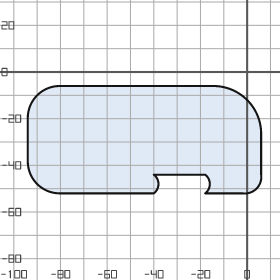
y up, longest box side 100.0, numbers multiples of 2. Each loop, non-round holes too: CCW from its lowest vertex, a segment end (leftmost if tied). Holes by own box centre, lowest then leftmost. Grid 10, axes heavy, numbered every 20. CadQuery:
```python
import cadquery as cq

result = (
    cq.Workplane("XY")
    .moveTo(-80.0, -52.0)
    .lineTo(-40.0, -52.0)
    .threePointArc((-38.0, -48.0), (-40.0, -44.0))
    .lineTo(-18.0, -44.0)
    .threePointArc((-16.0, -48.0), (-18.0, -52.0))
    .lineTo(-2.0, -52.0)
    .threePointArc((4.0, -50.0), (6.0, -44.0))
    .lineTo(6.0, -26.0)
    .threePointArc((0.0, -12.0), (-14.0, -6.0))
    .lineTo(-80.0, -6.0)
    .threePointArc((-90.0, -10.0), (-94.0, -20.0))
    .lineTo(-94.0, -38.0)
    .threePointArc((-90.0, -48.0), (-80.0, -52.0))
    .close()
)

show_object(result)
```